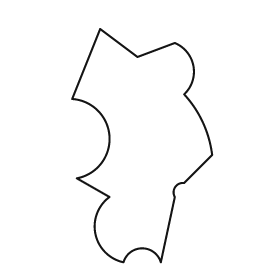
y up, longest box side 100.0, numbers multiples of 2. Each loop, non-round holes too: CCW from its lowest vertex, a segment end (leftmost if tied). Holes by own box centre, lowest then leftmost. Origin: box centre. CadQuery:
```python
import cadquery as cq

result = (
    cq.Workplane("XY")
    .moveTo(-8.0, -50.0)
    .threePointArc((0.0, -44.0), (8.0, -50.0))
    .lineTo(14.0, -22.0)
    .threePointArc((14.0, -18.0), (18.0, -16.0))
    .lineTo(30.0, -4.0)
    .threePointArc((26.0, 10.0), (18.0, 22.0))
    .threePointArc((22.0, 34.0), (14.0, 44.0))
    .lineTo(-2.0, 38.0)
    .lineTo(-18.0, 50.0)
    .lineTo(-30.0, 20.0)
    .threePointArc((-14.0, 4.0), (-28.0, -14.0))
    .lineTo(-14.0, -22.0)
    .threePointArc((-20.0, -38.0), (-8.0, -50.0))
    .close()
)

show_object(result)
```